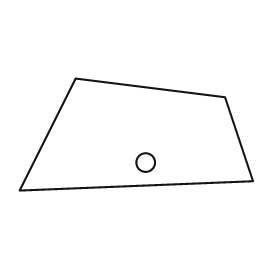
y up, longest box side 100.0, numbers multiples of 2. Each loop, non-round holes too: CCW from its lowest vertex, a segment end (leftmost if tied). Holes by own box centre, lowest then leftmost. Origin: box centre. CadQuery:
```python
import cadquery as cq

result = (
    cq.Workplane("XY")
    .moveTo(-50.0, -24.0)
    .lineTo(50.0, -20.0)
    .lineTo(38.0, 16.0)
    .lineTo(-26.0, 24.0)
    .close()
    .moveTo(4.0, -12.0)
    .circle(4.0)
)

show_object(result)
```